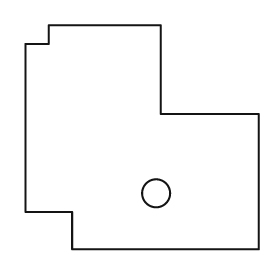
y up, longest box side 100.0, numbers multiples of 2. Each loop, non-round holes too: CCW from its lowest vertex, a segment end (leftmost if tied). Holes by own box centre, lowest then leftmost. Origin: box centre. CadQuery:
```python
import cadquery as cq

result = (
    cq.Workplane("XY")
    .moveTo(-30.0, -48.0)
    .lineTo(50.0, -48.0)
    .lineTo(50.0, 10.0)
    .lineTo(8.0, 10.0)
    .lineTo(8.0, 48.0)
    .lineTo(-40.0, 48.0)
    .lineTo(-40.0, 40.0)
    .lineTo(-50.0, 40.0)
    .lineTo(-50.0, -32.0)
    .lineTo(-30.0, -32.0)
    .close()
    .moveTo(6.0, -24.0)
    .circle(6.0)
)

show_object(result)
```